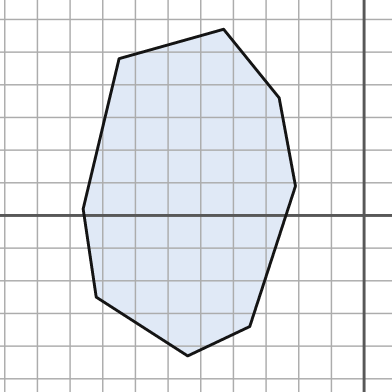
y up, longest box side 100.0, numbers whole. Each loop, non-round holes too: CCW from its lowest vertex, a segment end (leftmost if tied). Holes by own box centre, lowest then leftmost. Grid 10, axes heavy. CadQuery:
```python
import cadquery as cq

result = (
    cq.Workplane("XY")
    .moveTo(-54.0, -43.0)
    .lineTo(-35.0, -34.0)
    .lineTo(-21.0, 9.0)
    .lineTo(-26.0, 36.0)
    .lineTo(-43.0, 57.0)
    .lineTo(-75.0, 48.0)
    .lineTo(-86.0, 2.0)
    .lineTo(-82.0, -25.0)
    .close()
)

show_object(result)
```